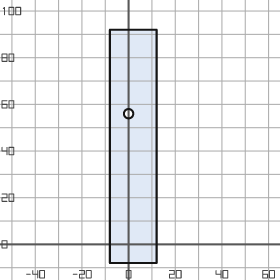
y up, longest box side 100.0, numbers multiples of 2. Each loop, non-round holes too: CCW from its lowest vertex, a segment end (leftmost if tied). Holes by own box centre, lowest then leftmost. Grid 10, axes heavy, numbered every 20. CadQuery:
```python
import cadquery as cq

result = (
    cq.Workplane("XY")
    .moveTo(-8.0, -8.0)
    .lineTo(12.0, -8.0)
    .lineTo(12.0, 92.0)
    .lineTo(-8.0, 92.0)
    .close()
    .moveTo(0.0, 56.0)
    .circle(2.0)
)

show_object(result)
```